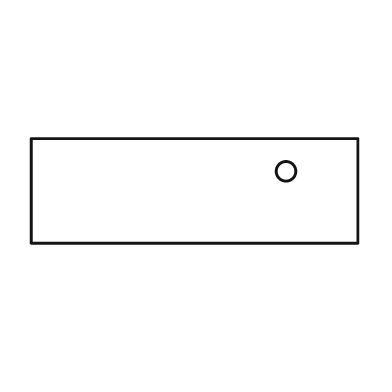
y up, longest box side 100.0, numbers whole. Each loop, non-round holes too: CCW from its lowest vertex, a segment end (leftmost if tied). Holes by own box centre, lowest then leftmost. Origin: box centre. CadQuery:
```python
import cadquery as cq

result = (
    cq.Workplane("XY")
    .moveTo(-50.0, -16.0)
    .lineTo(50.0, -16.0)
    .lineTo(50.0, 16.0)
    .lineTo(-50.0, 16.0)
    .close()
    .moveTo(28.0, 6.0)
    .circle(3.0)
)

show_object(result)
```